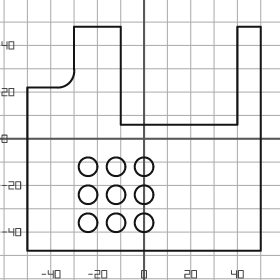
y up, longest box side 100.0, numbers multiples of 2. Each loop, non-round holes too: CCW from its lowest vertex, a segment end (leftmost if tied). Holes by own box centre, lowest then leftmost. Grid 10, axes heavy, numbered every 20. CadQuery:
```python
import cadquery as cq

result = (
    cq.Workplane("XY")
    .moveTo(-50.0, -48.0)
    .lineTo(50.0, -48.0)
    .lineTo(50.0, 48.0)
    .lineTo(40.0, 48.0)
    .lineTo(40.0, 6.0)
    .lineTo(-10.0, 6.0)
    .lineTo(-10.0, 48.0)
    .lineTo(-30.0, 48.0)
    .lineTo(-30.0, 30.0)
    .threePointArc((-32.0, 24.0), (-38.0, 22.0))
    .lineTo(-50.0, 22.0)
    .close()
    .moveTo(-24.0, -36.0)
    .circle(4.0)
    .moveTo(-12.0, -36.0)
    .circle(4.0)
    .moveTo(0.0, -36.0)
    .circle(4.0)
    .moveTo(-24.0, -24.0)
    .circle(4.0)
    .moveTo(-12.0, -24.0)
    .circle(4.0)
    .moveTo(0.0, -24.0)
    .circle(4.0)
    .moveTo(-24.0, -12.0)
    .circle(4.0)
    .moveTo(-12.0, -12.0)
    .circle(4.0)
    .moveTo(0.0, -12.0)
    .circle(4.0)
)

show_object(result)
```